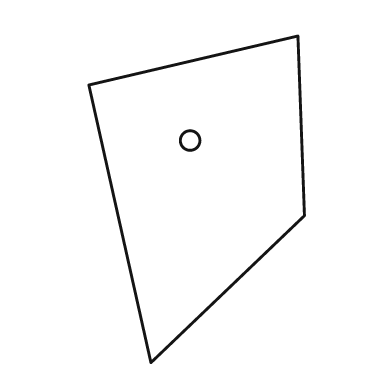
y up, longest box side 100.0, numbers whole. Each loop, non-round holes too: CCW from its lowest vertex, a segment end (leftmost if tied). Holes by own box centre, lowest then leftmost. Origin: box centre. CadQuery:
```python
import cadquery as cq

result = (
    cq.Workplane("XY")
    .moveTo(-14.0, -50.0)
    .lineTo(33.0, -5.0)
    .lineTo(31.0, 50.0)
    .lineTo(-33.0, 35.0)
    .close()
    .moveTo(-2.0, 18.0)
    .circle(3.0)
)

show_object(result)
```